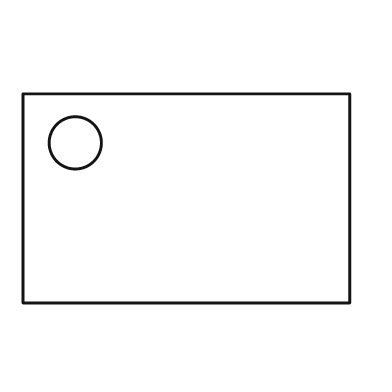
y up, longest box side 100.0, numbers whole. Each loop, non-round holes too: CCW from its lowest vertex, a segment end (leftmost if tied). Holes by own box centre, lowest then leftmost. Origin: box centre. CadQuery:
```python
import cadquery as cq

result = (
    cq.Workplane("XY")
    .moveTo(-50.0, -32.0)
    .lineTo(50.0, -32.0)
    .lineTo(50.0, 32.0)
    .lineTo(-50.0, 32.0)
    .close()
    .moveTo(-34.0, 17.0)
    .circle(8.0)
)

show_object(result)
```